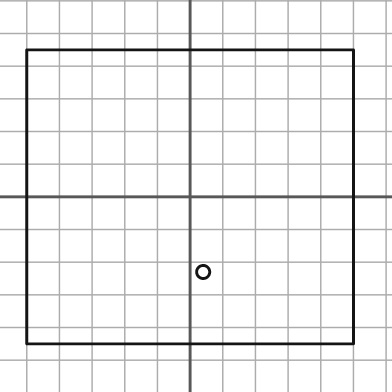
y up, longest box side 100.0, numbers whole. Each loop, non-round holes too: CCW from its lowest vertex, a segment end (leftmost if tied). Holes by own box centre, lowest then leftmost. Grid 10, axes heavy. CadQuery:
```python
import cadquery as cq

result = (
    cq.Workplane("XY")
    .moveTo(-50.0, -45.0)
    .lineTo(50.0, -45.0)
    .lineTo(50.0, 45.0)
    .lineTo(-50.0, 45.0)
    .close()
    .moveTo(4.0, -23.0)
    .circle(2.0)
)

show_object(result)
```